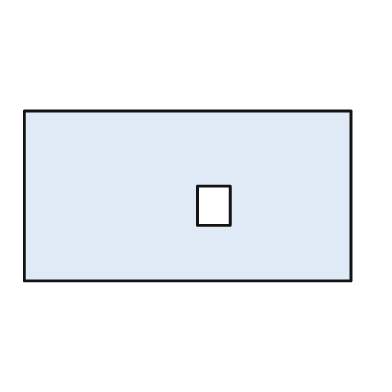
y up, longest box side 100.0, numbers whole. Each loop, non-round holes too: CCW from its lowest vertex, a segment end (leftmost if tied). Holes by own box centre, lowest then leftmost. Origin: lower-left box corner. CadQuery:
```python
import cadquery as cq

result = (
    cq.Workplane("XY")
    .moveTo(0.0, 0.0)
    .lineTo(100.0, 0.0)
    .lineTo(100.0, 52.0)
    .lineTo(0.0, 52.0)
    .close()
    .moveTo(53.0, 17.0)
    .lineTo(63.0, 17.0)
    .lineTo(63.0, 29.0)
    .lineTo(53.0, 29.0)
    .close()
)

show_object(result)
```